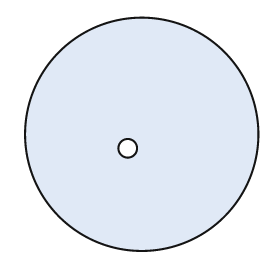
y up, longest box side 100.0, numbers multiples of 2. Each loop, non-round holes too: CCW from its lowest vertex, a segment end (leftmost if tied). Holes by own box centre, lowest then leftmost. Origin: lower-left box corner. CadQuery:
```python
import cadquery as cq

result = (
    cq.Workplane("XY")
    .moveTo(50.0, 50.0)
    .circle(50.0)
    .moveTo(44.0, 44.0)
    .circle(4.0)
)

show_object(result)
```